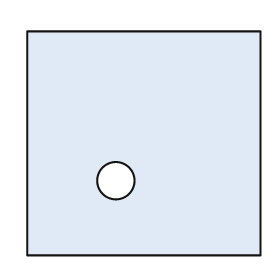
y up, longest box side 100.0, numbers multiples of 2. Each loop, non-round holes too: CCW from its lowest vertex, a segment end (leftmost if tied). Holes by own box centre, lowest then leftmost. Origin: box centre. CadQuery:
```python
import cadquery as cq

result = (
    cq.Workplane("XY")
    .moveTo(-50.0, -48.0)
    .lineTo(50.0, -48.0)
    .lineTo(50.0, 48.0)
    .lineTo(-50.0, 48.0)
    .close()
    .moveTo(-12.0, -16.0)
    .circle(8.0)
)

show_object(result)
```